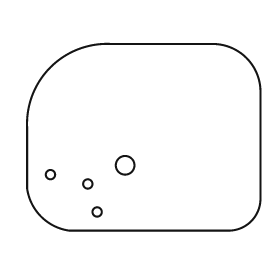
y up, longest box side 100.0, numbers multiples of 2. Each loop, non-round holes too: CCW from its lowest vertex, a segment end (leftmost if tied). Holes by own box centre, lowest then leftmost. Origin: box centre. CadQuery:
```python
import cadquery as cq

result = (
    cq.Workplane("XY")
    .moveTo(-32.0, -40.0)
    .lineTo(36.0, -40.0)
    .threePointArc((46.0, -36.0), (50.0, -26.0))
    .lineTo(50.0, 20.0)
    .threePointArc((44.0, 34.0), (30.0, 40.0))
    .lineTo(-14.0, 40.0)
    .threePointArc((-40.0, 30.0), (-50.0, 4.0))
    .lineTo(-50.0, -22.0)
    .threePointArc((-44.0, -34.0), (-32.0, -40.0))
    .close()
    .moveTo(-20.0, -32.0)
    .circle(2.0)
    .moveTo(-24.0, -20.0)
    .circle(2.0)
    .moveTo(-40.0, -16.0)
    .circle(2.0)
    .moveTo(-8.0, -12.0)
    .circle(4.0)
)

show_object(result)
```